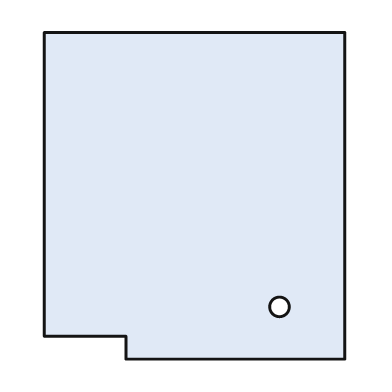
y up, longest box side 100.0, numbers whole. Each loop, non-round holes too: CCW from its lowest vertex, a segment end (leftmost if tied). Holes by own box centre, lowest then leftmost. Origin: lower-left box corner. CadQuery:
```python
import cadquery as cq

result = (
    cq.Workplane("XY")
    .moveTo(25.0, 0.0)
    .lineTo(92.0, 0.0)
    .lineTo(92.0, 100.0)
    .lineTo(0.0, 100.0)
    .lineTo(0.0, 7.0)
    .lineTo(25.0, 7.0)
    .close()
    .moveTo(72.0, 16.0)
    .circle(3.0)
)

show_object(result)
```